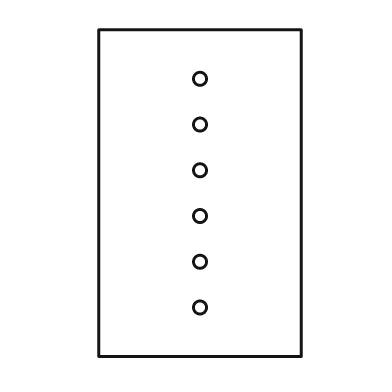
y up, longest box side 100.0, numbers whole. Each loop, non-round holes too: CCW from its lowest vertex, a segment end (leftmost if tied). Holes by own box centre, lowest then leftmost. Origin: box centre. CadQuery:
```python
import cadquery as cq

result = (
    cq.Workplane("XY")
    .moveTo(-31.0, -50.0)
    .lineTo(31.0, -50.0)
    .lineTo(31.0, 50.0)
    .lineTo(-31.0, 50.0)
    .close()
    .moveTo(0.0, -35.0)
    .circle(2.0)
    .moveTo(0.0, -21.0)
    .circle(2.0)
    .moveTo(0.0, -7.0)
    .circle(2.0)
    .moveTo(0.0, 7.0)
    .circle(2.0)
    .moveTo(0.0, 21.0)
    .circle(2.0)
    .moveTo(0.0, 35.0)
    .circle(2.0)
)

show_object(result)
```